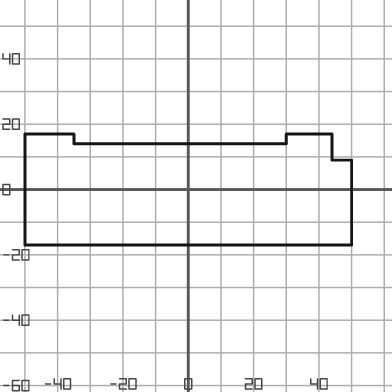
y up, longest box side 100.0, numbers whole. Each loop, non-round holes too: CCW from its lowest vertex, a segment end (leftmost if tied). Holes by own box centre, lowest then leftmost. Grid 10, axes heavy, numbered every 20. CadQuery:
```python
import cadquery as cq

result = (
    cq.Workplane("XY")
    .moveTo(-50.0, -17.0)
    .lineTo(50.0, -17.0)
    .lineTo(50.0, 9.0)
    .lineTo(44.0, 9.0)
    .lineTo(44.0, 17.0)
    .lineTo(30.0, 17.0)
    .lineTo(30.0, 14.0)
    .lineTo(-35.0, 14.0)
    .lineTo(-35.0, 17.0)
    .lineTo(-50.0, 17.0)
    .close()
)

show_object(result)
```